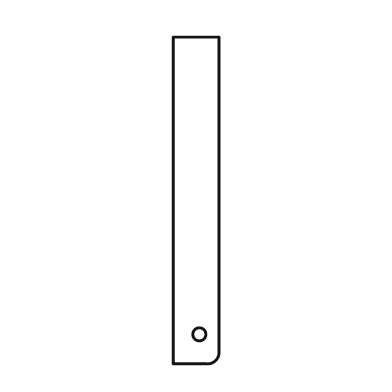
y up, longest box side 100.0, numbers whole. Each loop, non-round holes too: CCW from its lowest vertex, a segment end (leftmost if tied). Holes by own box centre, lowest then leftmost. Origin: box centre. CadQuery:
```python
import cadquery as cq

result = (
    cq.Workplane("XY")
    .moveTo(-7.0, -50.0)
    .lineTo(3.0, -50.0)
    .threePointArc((6.0, -49.0), (7.0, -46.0))
    .lineTo(7.0, 50.0)
    .lineTo(-7.0, 50.0)
    .close()
    .moveTo(1.0, -41.0)
    .circle(2.0)
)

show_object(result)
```